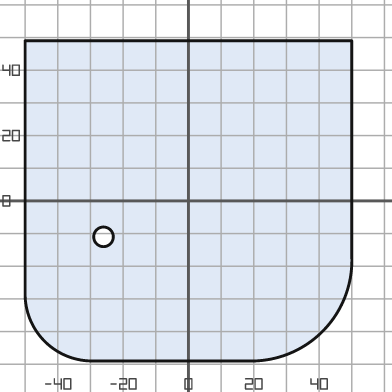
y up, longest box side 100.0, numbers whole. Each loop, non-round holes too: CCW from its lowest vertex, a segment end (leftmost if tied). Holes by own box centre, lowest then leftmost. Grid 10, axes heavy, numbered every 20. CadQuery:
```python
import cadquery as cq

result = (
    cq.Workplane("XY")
    .moveTo(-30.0, -49.0)
    .lineTo(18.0, -49.0)
    .threePointArc((41.0, -40.0), (50.0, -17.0))
    .lineTo(50.0, 49.0)
    .lineTo(-50.0, 49.0)
    .lineTo(-50.0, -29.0)
    .threePointArc((-44.0, -43.0), (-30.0, -49.0))
    .close()
    .moveTo(-26.0, -11.0)
    .circle(3.0)
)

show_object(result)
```